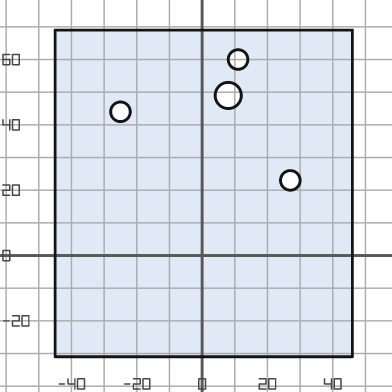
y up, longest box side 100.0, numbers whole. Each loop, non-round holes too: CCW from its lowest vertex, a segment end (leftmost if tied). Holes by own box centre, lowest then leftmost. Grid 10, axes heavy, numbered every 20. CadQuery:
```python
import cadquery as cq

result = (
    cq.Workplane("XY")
    .moveTo(-45.0, -31.0)
    .lineTo(46.0, -31.0)
    .lineTo(46.0, 69.0)
    .lineTo(-45.0, 69.0)
    .close()
    .moveTo(27.0, 23.0)
    .circle(3.0)
    .moveTo(-25.0, 44.0)
    .circle(3.0)
    .moveTo(8.0, 49.0)
    .circle(4.0)
    .moveTo(11.0, 60.0)
    .circle(3.0)
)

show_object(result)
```